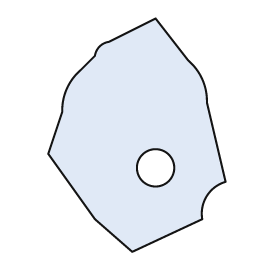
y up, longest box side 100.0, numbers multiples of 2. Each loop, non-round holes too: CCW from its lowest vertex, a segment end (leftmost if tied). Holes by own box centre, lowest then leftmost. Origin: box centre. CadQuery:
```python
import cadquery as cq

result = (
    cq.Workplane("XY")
    .moveTo(-2.0, -50.0)
    .lineTo(28.0, -36.0)
    .threePointArc((30.0, -26.0), (38.0, -20.0))
    .lineTo(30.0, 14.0)
    .threePointArc((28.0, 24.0), (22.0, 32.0))
    .lineTo(8.0, 50.0)
    .lineTo(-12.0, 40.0)
    .threePointArc((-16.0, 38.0), (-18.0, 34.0))
    .lineTo(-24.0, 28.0)
    .threePointArc((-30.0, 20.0), (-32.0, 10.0))
    .lineTo(-38.0, -8.0)
    .lineTo(-18.0, -36.0)
    .close()
    .moveTo(8.0, -14.0)
    .circle(8.0)
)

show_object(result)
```